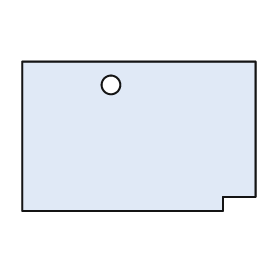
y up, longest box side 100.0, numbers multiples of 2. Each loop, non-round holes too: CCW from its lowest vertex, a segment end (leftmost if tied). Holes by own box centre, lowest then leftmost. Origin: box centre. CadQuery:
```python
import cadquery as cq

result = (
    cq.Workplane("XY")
    .moveTo(-50.0, -32.0)
    .lineTo(36.0, -32.0)
    .lineTo(36.0, -26.0)
    .lineTo(50.0, -26.0)
    .lineTo(50.0, 32.0)
    .lineTo(-50.0, 32.0)
    .close()
    .moveTo(-12.0, 22.0)
    .circle(4.0)
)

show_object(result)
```